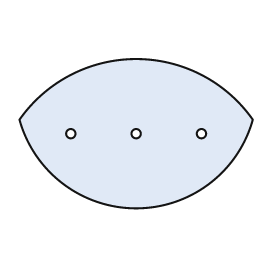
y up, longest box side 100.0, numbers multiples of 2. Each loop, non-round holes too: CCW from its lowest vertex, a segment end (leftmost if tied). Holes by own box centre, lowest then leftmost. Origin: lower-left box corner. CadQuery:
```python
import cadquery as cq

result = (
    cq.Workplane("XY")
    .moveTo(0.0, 38.0)
    .threePointArc((50.0, 0.0), (100.0, 38.0))
    .threePointArc((50.0, 64.0), (0.0, 38.0))
    .close()
    .moveTo(22.0, 32.0)
    .circle(2.0)
    .moveTo(50.0, 32.0)
    .circle(2.0)
    .moveTo(78.0, 32.0)
    .circle(2.0)
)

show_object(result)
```